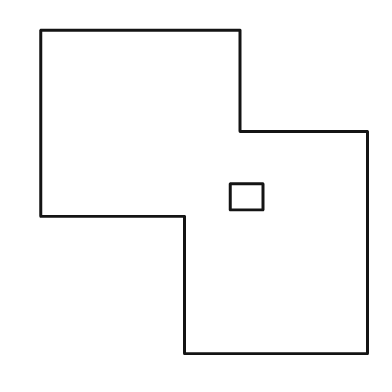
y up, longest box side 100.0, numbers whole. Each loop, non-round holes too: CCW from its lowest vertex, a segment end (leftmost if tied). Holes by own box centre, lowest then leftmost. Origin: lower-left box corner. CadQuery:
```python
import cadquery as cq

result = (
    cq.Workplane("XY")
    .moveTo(44.0, 0.0)
    .lineTo(100.0, 0.0)
    .lineTo(100.0, 68.0)
    .lineTo(61.0, 68.0)
    .lineTo(61.0, 99.0)
    .lineTo(0.0, 99.0)
    .lineTo(0.0, 42.0)
    .lineTo(44.0, 42.0)
    .close()
    .moveTo(58.0, 44.0)
    .lineTo(68.0, 44.0)
    .lineTo(68.0, 52.0)
    .lineTo(58.0, 52.0)
    .close()
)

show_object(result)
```